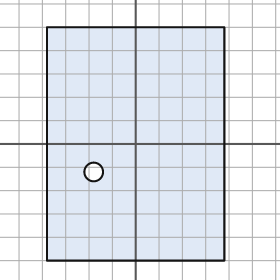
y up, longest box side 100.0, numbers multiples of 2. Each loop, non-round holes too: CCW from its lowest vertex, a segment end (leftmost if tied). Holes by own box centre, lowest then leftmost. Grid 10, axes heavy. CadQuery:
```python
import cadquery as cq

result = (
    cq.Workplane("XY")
    .moveTo(-38.0, -50.0)
    .lineTo(38.0, -50.0)
    .lineTo(38.0, 50.0)
    .lineTo(-38.0, 50.0)
    .close()
    .moveTo(-18.0, -12.0)
    .circle(4.0)
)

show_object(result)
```